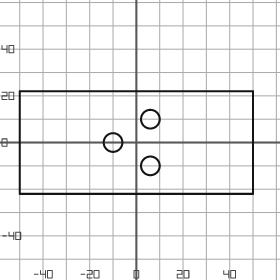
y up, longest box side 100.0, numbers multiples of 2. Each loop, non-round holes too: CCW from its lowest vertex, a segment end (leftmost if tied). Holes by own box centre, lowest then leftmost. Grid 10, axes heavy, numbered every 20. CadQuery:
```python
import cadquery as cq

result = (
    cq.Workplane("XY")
    .moveTo(-50.0, -22.0)
    .lineTo(50.0, -22.0)
    .lineTo(50.0, 22.0)
    .lineTo(-50.0, 22.0)
    .close()
    .moveTo(6.0, -10.0)
    .circle(4.0)
    .moveTo(-10.0, 0.0)
    .circle(4.0)
    .moveTo(6.0, 10.0)
    .circle(4.0)
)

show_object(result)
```